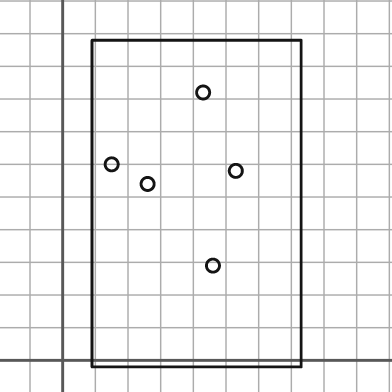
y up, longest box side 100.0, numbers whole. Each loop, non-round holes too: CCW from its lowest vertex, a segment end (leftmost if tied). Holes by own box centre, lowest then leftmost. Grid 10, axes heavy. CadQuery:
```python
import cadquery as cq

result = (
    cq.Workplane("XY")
    .moveTo(9.0, -2.0)
    .lineTo(73.0, -2.0)
    .lineTo(73.0, 98.0)
    .lineTo(9.0, 98.0)
    .close()
    .moveTo(46.0, 29.0)
    .circle(2.0)
    .moveTo(26.0, 54.0)
    .circle(2.0)
    .moveTo(53.0, 58.0)
    .circle(2.0)
    .moveTo(15.0, 60.0)
    .circle(2.0)
    .moveTo(43.0, 82.0)
    .circle(2.0)
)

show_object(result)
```